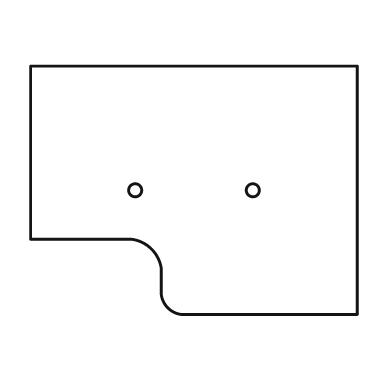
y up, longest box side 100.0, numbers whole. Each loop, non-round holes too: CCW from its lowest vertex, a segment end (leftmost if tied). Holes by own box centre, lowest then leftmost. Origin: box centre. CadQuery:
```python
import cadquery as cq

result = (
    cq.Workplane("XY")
    .moveTo(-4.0, -38.0)
    .lineTo(50.0, -38.0)
    .lineTo(50.0, 38.0)
    .lineTo(-50.0, 38.0)
    .lineTo(-50.0, -15.0)
    .lineTo(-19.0, -15.0)
    .threePointArc((-13.0, -18.0), (-10.0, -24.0))
    .lineTo(-10.0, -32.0)
    .threePointArc((-8.0, -36.0), (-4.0, -38.0))
    .close()
    .moveTo(-18.0, 0.0)
    .circle(2.0)
    .moveTo(18.0, 0.0)
    .circle(2.0)
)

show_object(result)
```